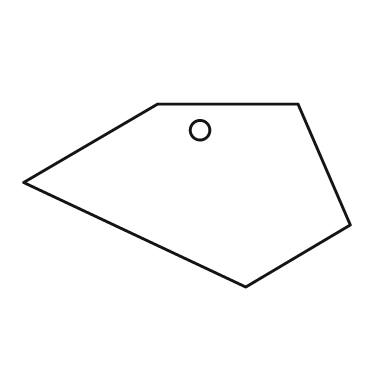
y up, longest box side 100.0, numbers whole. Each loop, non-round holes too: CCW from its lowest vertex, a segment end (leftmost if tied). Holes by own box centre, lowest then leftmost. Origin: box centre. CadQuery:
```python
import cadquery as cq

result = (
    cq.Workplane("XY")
    .moveTo(18.0, -28.0)
    .lineTo(50.0, -9.0)
    .lineTo(34.0, 28.0)
    .lineTo(-9.0, 28.0)
    .lineTo(-50.0, 4.0)
    .close()
    .moveTo(4.0, 20.0)
    .circle(3.0)
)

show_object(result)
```